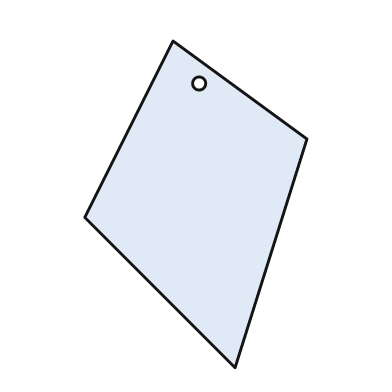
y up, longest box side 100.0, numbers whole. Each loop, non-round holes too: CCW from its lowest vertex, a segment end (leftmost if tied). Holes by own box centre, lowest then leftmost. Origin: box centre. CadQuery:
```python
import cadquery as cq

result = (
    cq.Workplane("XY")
    .moveTo(12.0, -50.0)
    .lineTo(34.0, 20.0)
    .lineTo(-7.0, 50.0)
    .lineTo(-34.0, -4.0)
    .close()
    .moveTo(1.0, 37.0)
    .circle(2.0)
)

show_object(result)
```